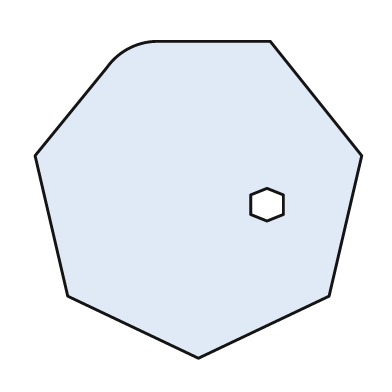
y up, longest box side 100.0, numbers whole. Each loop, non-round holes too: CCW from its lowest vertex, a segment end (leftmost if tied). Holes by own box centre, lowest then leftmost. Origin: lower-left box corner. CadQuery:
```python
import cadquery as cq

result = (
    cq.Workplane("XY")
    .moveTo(50.0, 0.0)
    .lineTo(90.0, 19.0)
    .lineTo(100.0, 62.0)
    .lineTo(72.0, 97.0)
    .lineTo(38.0, 97.0)
    .threePointArc((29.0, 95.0), (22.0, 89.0))
    .lineTo(0.0, 62.0)
    .lineTo(10.0, 19.0)
    .close()
    .moveTo(71.0, 42.0)
    .lineTo(76.0, 44.0)
    .lineTo(76.0, 50.0)
    .lineTo(71.0, 52.0)
    .lineTo(66.0, 50.0)
    .lineTo(66.0, 44.0)
    .close()
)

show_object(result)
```